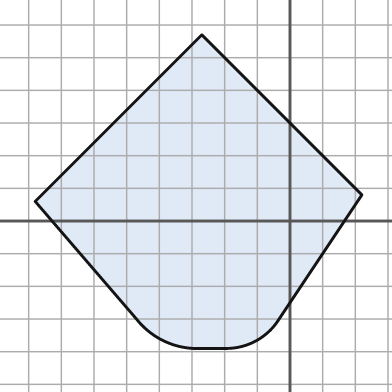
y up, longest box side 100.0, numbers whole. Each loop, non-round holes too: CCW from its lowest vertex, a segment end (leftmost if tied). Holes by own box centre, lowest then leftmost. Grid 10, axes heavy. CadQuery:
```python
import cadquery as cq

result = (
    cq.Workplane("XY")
    .moveTo(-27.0, -39.0)
    .lineTo(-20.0, -39.0)
    .threePointArc((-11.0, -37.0), (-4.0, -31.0))
    .lineTo(22.0, 8.0)
    .lineTo(-27.0, 57.0)
    .lineTo(-78.0, 6.0)
    .lineTo(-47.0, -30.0)
    .threePointArc((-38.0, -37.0), (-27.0, -39.0))
    .close()
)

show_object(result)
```